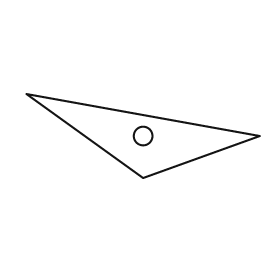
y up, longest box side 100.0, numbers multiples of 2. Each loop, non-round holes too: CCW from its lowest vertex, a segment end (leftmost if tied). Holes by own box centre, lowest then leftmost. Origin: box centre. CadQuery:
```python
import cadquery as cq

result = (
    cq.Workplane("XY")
    .moveTo(0.0, -18.0)
    .lineTo(50.0, 0.0)
    .lineTo(-50.0, 18.0)
    .close()
    .moveTo(0.0, 0.0)
    .circle(4.0)
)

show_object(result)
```